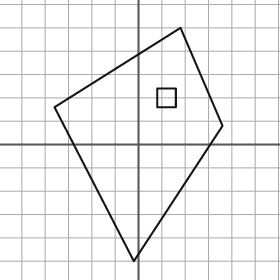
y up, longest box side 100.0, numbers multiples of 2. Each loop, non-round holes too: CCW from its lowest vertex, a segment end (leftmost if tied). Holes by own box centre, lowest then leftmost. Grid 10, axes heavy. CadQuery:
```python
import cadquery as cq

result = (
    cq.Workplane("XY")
    .moveTo(-2.0, -50.0)
    .lineTo(36.0, 8.0)
    .lineTo(18.0, 50.0)
    .lineTo(-36.0, 16.0)
    .close()
    .moveTo(8.0, 16.0)
    .lineTo(16.0, 16.0)
    .lineTo(16.0, 24.0)
    .lineTo(8.0, 24.0)
    .close()
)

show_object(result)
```